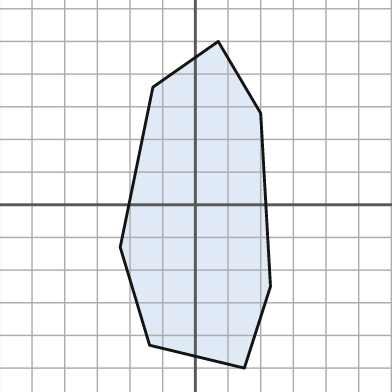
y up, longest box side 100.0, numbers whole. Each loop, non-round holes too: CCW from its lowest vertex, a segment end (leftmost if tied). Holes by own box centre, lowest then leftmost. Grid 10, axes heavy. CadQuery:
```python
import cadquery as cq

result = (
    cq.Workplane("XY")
    .moveTo(15.0, -50.0)
    .lineTo(23.0, -25.0)
    .lineTo(20.0, 28.0)
    .lineTo(7.0, 50.0)
    .lineTo(-13.0, 36.0)
    .lineTo(-23.0, -13.0)
    .lineTo(-14.0, -43.0)
    .close()
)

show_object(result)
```